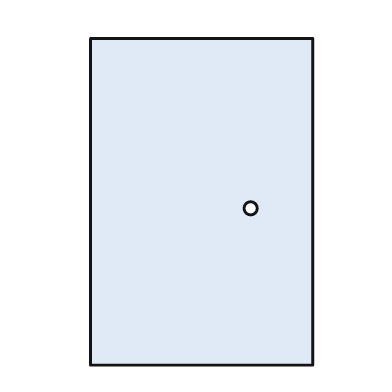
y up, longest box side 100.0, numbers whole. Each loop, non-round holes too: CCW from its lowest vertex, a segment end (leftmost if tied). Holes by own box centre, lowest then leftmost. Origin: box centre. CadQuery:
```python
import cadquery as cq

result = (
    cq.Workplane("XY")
    .moveTo(-34.0, -50.0)
    .lineTo(34.0, -50.0)
    .lineTo(34.0, 50.0)
    .lineTo(-34.0, 50.0)
    .close()
    .moveTo(15.0, -2.0)
    .circle(2.0)
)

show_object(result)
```